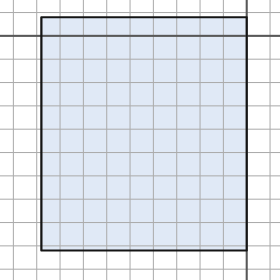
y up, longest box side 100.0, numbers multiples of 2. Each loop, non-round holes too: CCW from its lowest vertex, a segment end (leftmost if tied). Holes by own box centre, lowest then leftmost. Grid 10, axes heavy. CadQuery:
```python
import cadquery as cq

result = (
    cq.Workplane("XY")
    .moveTo(-88.0, -92.0)
    .lineTo(0.0, -92.0)
    .lineTo(0.0, 8.0)
    .lineTo(-88.0, 8.0)
    .close()
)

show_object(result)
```